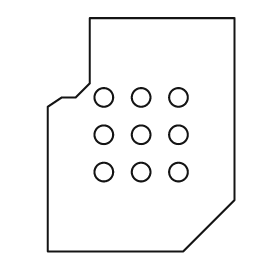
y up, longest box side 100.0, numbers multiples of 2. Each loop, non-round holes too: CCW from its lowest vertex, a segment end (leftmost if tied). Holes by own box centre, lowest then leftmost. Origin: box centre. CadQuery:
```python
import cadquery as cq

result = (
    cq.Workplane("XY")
    .moveTo(-40.0, -50.0)
    .lineTo(18.0, -50.0)
    .lineTo(40.0, -28.0)
    .lineTo(40.0, 50.0)
    .lineTo(-22.0, 50.0)
    .lineTo(-22.0, 22.0)
    .lineTo(-28.0, 16.0)
    .lineTo(-34.0, 16.0)
    .lineTo(-40.0, 12.0)
    .close()
    .moveTo(-16.0, -16.0)
    .circle(4.0)
    .moveTo(0.0, -16.0)
    .circle(4.0)
    .moveTo(16.0, -16.0)
    .circle(4.0)
    .moveTo(-16.0, 0.0)
    .circle(4.0)
    .moveTo(0.0, 0.0)
    .circle(4.0)
    .moveTo(16.0, 0.0)
    .circle(4.0)
    .moveTo(-16.0, 16.0)
    .circle(4.0)
    .moveTo(0.0, 16.0)
    .circle(4.0)
    .moveTo(16.0, 16.0)
    .circle(4.0)
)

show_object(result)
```